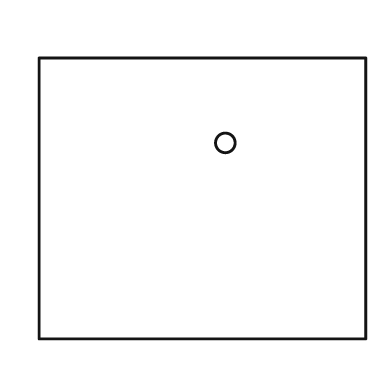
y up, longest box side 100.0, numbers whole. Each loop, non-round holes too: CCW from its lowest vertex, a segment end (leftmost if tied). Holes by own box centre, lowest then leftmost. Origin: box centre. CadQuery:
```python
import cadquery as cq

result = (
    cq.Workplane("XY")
    .moveTo(-50.0, -43.0)
    .lineTo(50.0, -43.0)
    .lineTo(50.0, 43.0)
    .lineTo(-50.0, 43.0)
    .close()
    .moveTo(7.0, 17.0)
    .circle(3.0)
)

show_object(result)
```